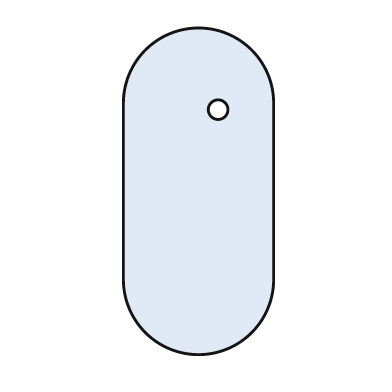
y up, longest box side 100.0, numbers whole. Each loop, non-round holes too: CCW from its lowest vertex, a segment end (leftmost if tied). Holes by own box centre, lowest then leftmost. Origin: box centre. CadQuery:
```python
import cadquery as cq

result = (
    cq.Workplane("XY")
    .moveTo(-23.0, -27.0)
    .threePointArc((0.0, -50.0), (23.0, -27.0))
    .lineTo(23.0, 27.0)
    .threePointArc((0.0, 50.0), (-23.0, 27.0))
    .close()
    .moveTo(6.0, 25.0)
    .circle(3.0)
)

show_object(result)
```